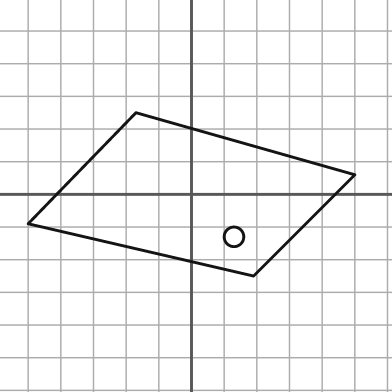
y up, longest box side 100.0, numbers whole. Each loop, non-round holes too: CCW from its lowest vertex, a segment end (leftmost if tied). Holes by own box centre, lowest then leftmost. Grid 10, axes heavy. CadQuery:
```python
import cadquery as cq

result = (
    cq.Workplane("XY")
    .moveTo(19.0, -25.0)
    .lineTo(50.0, 6.0)
    .lineTo(-17.0, 25.0)
    .lineTo(-50.0, -9.0)
    .close()
    .moveTo(13.0, -13.0)
    .circle(3.0)
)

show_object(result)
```